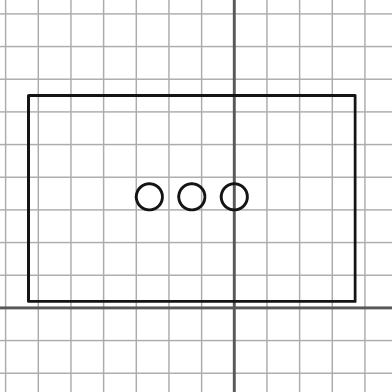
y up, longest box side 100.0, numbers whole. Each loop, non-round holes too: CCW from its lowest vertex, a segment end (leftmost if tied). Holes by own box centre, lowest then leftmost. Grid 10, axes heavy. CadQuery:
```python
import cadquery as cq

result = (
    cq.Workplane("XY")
    .moveTo(-63.0, 2.0)
    .lineTo(37.0, 2.0)
    .lineTo(37.0, 65.0)
    .lineTo(-63.0, 65.0)
    .close()
    .moveTo(-26.0, 34.0)
    .circle(4.0)
    .moveTo(-13.0, 34.0)
    .circle(4.0)
    .moveTo(0.0, 34.0)
    .circle(4.0)
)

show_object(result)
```